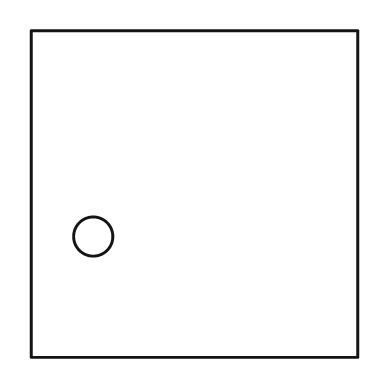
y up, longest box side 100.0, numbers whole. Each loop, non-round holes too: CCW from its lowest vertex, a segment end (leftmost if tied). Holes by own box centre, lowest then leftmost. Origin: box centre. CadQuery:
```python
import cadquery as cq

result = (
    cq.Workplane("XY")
    .moveTo(-50.0, -50.0)
    .lineTo(50.0, -50.0)
    .lineTo(50.0, 50.0)
    .lineTo(-50.0, 50.0)
    .close()
    .moveTo(-31.0, -13.0)
    .circle(6.0)
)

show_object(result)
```